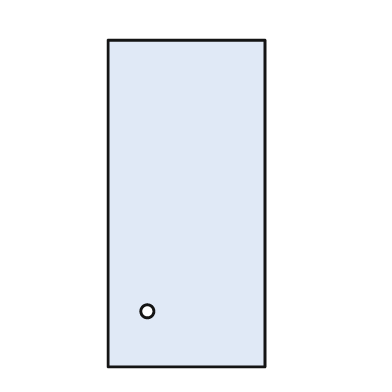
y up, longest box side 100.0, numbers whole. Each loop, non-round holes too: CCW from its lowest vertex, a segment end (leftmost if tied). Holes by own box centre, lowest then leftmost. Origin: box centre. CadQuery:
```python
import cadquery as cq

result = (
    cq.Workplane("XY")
    .moveTo(-24.0, -50.0)
    .lineTo(24.0, -50.0)
    .lineTo(24.0, 50.0)
    .lineTo(-24.0, 50.0)
    .close()
    .moveTo(-12.0, -33.0)
    .circle(2.0)
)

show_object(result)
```